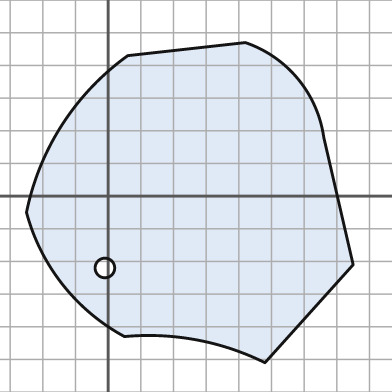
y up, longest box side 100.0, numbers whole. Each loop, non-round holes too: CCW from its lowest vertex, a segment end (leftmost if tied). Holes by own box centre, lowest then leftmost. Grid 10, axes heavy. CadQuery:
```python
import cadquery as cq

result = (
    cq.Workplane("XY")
    .moveTo(48.0, -51.0)
    .lineTo(75.0, -21.0)
    .lineTo(66.0, 18.0)
    .threePointArc((58.0, 36.0), (42.0, 47.0))
    .lineTo(6.0, 43.0)
    .threePointArc((-14.0, 22.0), (-25.0, -5.0))
    .threePointArc((-14.0, -27.0), (5.0, -43.0))
    .threePointArc((27.0, -44.0), (48.0, -51.0))
    .close()
    .moveTo(-1.0, -22.0)
    .circle(3.0)
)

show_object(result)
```